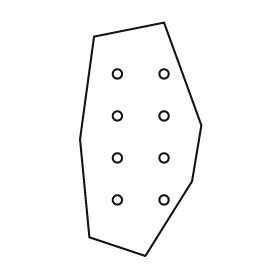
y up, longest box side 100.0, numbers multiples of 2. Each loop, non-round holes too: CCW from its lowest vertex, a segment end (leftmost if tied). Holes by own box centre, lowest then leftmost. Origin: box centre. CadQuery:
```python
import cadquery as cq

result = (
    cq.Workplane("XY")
    .moveTo(2.0, -50.0)
    .lineTo(22.0, -18.0)
    .lineTo(26.0, 6.0)
    .lineTo(10.0, 50.0)
    .lineTo(-20.0, 44.0)
    .lineTo(-26.0, 0.0)
    .lineTo(-22.0, -42.0)
    .close()
    .moveTo(-10.0, -26.0)
    .circle(2.0)
    .moveTo(10.0, -26.0)
    .circle(2.0)
    .moveTo(-10.0, -8.0)
    .circle(2.0)
    .moveTo(10.0, -8.0)
    .circle(2.0)
    .moveTo(-10.0, 10.0)
    .circle(2.0)
    .moveTo(10.0, 10.0)
    .circle(2.0)
    .moveTo(-10.0, 28.0)
    .circle(2.0)
    .moveTo(10.0, 28.0)
    .circle(2.0)
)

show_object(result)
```